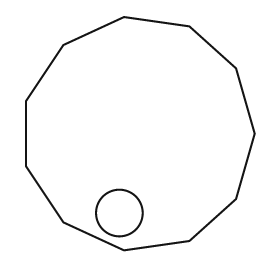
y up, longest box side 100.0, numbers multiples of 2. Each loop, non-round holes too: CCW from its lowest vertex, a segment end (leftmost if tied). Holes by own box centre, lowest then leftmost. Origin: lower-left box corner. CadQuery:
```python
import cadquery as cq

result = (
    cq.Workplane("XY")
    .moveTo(42.0, 0.0)
    .lineTo(70.0, 4.0)
    .lineTo(90.0, 22.0)
    .lineTo(98.0, 50.0)
    .lineTo(90.0, 78.0)
    .lineTo(70.0, 96.0)
    .lineTo(42.0, 100.0)
    .lineTo(16.0, 88.0)
    .lineTo(0.0, 64.0)
    .lineTo(0.0, 36.0)
    .lineTo(16.0, 12.0)
    .close()
    .moveTo(40.0, 16.0)
    .circle(10.0)
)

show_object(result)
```